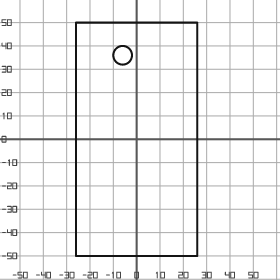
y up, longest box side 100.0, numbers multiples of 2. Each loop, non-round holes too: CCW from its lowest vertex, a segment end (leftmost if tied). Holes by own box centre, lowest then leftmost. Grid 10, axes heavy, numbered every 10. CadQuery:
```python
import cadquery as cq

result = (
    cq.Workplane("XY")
    .moveTo(-26.0, -50.0)
    .lineTo(26.0, -50.0)
    .lineTo(26.0, 50.0)
    .lineTo(-26.0, 50.0)
    .close()
    .moveTo(-6.0, 36.0)
    .circle(4.0)
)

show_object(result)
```